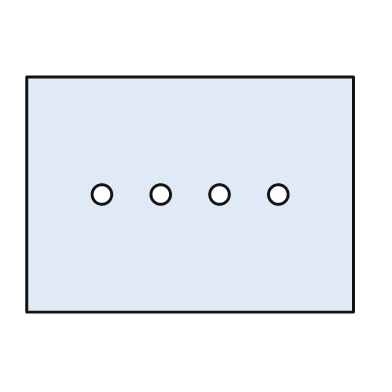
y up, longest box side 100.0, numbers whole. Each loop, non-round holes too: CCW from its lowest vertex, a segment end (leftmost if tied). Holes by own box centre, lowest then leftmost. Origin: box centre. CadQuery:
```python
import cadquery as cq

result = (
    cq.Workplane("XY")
    .moveTo(-50.0, -36.0)
    .lineTo(50.0, -36.0)
    .lineTo(50.0, 36.0)
    .lineTo(-50.0, 36.0)
    .close()
    .moveTo(-27.0, 0.0)
    .circle(3.0)
    .moveTo(-9.0, 0.0)
    .circle(3.0)
    .moveTo(9.0, 0.0)
    .circle(3.0)
    .moveTo(27.0, 0.0)
    .circle(3.0)
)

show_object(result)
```